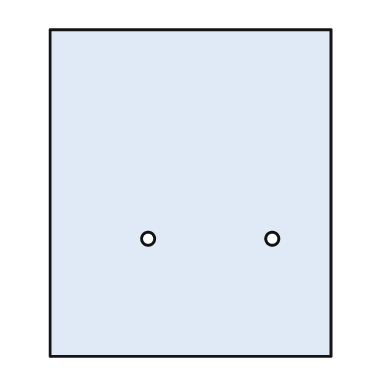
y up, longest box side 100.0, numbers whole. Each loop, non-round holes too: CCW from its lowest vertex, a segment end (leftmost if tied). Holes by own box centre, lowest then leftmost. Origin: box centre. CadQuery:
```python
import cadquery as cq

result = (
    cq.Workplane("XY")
    .moveTo(-43.0, -50.0)
    .lineTo(43.0, -50.0)
    .lineTo(43.0, 50.0)
    .lineTo(-43.0, 50.0)
    .close()
    .moveTo(-13.0, -14.0)
    .circle(2.0)
    .moveTo(25.0, -14.0)
    .circle(2.0)
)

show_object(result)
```